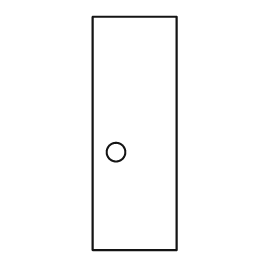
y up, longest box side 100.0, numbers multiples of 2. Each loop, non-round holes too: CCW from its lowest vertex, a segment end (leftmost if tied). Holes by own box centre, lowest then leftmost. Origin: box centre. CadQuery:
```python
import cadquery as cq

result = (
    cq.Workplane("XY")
    .moveTo(-18.0, -50.0)
    .lineTo(18.0, -50.0)
    .lineTo(18.0, 50.0)
    .lineTo(-18.0, 50.0)
    .close()
    .moveTo(-8.0, -8.0)
    .circle(4.0)
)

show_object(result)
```